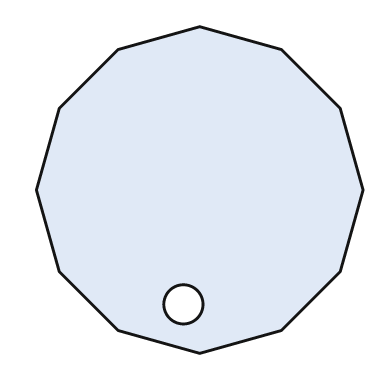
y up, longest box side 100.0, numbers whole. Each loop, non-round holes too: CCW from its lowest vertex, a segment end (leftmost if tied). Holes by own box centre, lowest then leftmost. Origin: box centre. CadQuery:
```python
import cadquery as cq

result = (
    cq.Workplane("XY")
    .moveTo(0.0, -50.0)
    .lineTo(25.0, -43.0)
    .lineTo(43.0, -25.0)
    .lineTo(50.0, 0.0)
    .lineTo(43.0, 25.0)
    .lineTo(25.0, 43.0)
    .lineTo(0.0, 50.0)
    .lineTo(-25.0, 43.0)
    .lineTo(-43.0, 25.0)
    .lineTo(-50.0, 0.0)
    .lineTo(-43.0, -25.0)
    .lineTo(-25.0, -43.0)
    .close()
    .moveTo(-5.0, -35.0)
    .circle(6.0)
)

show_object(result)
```